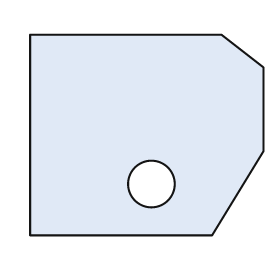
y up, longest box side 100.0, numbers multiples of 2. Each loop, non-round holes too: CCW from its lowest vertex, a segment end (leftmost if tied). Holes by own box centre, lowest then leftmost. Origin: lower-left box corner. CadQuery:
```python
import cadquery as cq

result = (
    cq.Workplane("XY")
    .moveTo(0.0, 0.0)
    .lineTo(78.0, 0.0)
    .lineTo(100.0, 36.0)
    .lineTo(100.0, 72.0)
    .lineTo(82.0, 86.0)
    .lineTo(0.0, 86.0)
    .close()
    .moveTo(52.0, 22.0)
    .circle(10.0)
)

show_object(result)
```